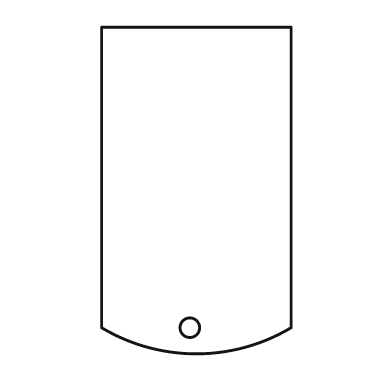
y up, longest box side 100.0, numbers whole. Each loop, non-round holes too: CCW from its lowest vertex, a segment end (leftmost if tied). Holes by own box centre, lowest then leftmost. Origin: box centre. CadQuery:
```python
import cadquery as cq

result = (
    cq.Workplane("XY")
    .moveTo(-29.0, -42.0)
    .threePointArc((0.0, -50.0), (29.0, -42.0))
    .lineTo(29.0, 50.0)
    .lineTo(-29.0, 50.0)
    .close()
    .moveTo(-2.0, -42.0)
    .circle(3.0)
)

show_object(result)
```